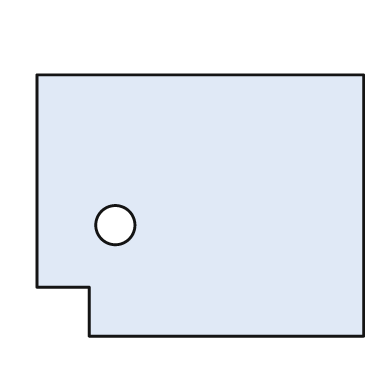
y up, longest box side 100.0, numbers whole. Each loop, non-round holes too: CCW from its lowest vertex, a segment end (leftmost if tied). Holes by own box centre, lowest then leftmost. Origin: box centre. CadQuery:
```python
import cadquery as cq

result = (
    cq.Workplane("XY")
    .moveTo(-34.0, -40.0)
    .lineTo(50.0, -40.0)
    .lineTo(50.0, 40.0)
    .lineTo(-50.0, 40.0)
    .lineTo(-50.0, -25.0)
    .lineTo(-34.0, -25.0)
    .close()
    .moveTo(-26.0, -6.0)
    .circle(6.0)
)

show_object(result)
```